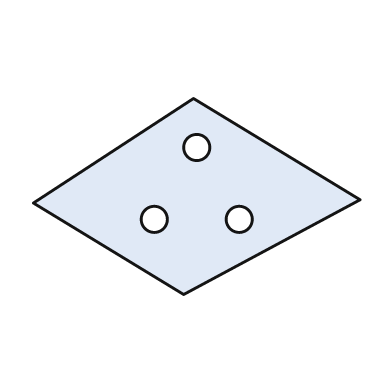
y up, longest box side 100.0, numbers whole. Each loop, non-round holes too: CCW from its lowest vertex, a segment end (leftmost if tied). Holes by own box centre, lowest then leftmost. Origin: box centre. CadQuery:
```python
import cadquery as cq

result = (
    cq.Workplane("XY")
    .moveTo(-4.0, -30.0)
    .lineTo(50.0, -1.0)
    .lineTo(-1.0, 30.0)
    .lineTo(-50.0, -2.0)
    .close()
    .moveTo(-13.0, -7.0)
    .circle(4.0)
    .moveTo(13.0, -7.0)
    .circle(4.0)
    .moveTo(0.0, 15.0)
    .circle(4.0)
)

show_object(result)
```